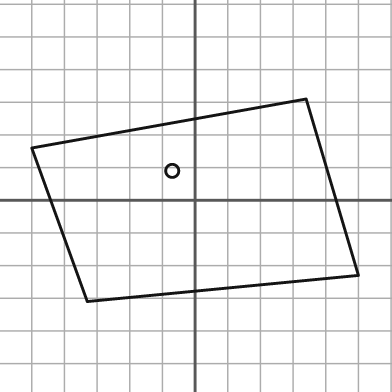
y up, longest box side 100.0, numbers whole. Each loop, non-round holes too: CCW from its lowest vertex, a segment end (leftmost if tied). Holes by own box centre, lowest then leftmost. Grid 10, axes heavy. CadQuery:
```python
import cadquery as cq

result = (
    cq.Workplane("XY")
    .moveTo(-33.0, -31.0)
    .lineTo(50.0, -23.0)
    .lineTo(34.0, 31.0)
    .lineTo(-50.0, 16.0)
    .close()
    .moveTo(-7.0, 9.0)
    .circle(2.0)
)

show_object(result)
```